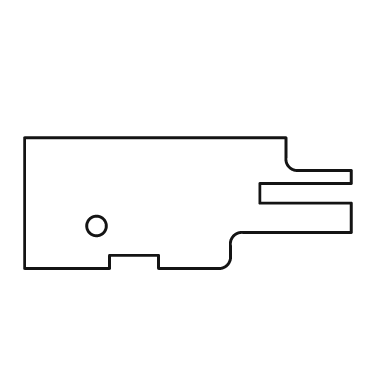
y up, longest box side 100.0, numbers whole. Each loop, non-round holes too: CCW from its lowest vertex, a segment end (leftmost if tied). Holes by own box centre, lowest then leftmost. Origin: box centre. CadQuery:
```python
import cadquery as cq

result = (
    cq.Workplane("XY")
    .moveTo(-50.0, -20.0)
    .lineTo(-24.0, -20.0)
    .lineTo(-24.0, -16.0)
    .lineTo(-9.0, -16.0)
    .lineTo(-9.0, -20.0)
    .lineTo(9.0, -20.0)
    .threePointArc((12.0, -19.0), (13.0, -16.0))
    .lineTo(13.0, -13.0)
    .threePointArc((14.0, -10.0), (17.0, -9.0))
    .lineTo(50.0, -9.0)
    .lineTo(50.0, 0.0)
    .lineTo(22.0, 0.0)
    .lineTo(22.0, 6.0)
    .lineTo(50.0, 6.0)
    .lineTo(50.0, 10.0)
    .lineTo(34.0, 10.0)
    .threePointArc((31.0, 11.0), (30.0, 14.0))
    .lineTo(30.0, 20.0)
    .lineTo(-50.0, 20.0)
    .close()
    .moveTo(-28.0, -7.0)
    .circle(3.0)
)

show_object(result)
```